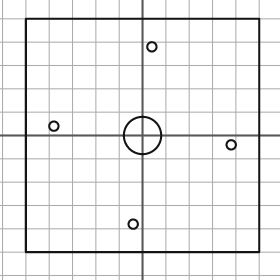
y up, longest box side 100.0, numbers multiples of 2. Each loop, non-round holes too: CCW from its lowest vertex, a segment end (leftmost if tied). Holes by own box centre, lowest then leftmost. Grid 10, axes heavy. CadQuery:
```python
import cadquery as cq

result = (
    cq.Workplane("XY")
    .moveTo(-50.0, -50.0)
    .lineTo(50.0, -50.0)
    .lineTo(50.0, 50.0)
    .lineTo(-50.0, 50.0)
    .close()
    .moveTo(-4.0, -38.0)
    .circle(2.0)
    .moveTo(38.0, -4.0)
    .circle(2.0)
    .moveTo(0.0, 0.0)
    .circle(8.0)
    .moveTo(-38.0, 4.0)
    .circle(2.0)
    .moveTo(4.0, 38.0)
    .circle(2.0)
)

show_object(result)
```